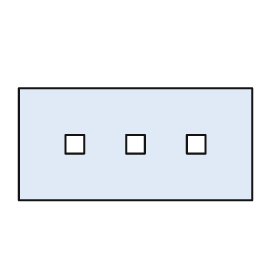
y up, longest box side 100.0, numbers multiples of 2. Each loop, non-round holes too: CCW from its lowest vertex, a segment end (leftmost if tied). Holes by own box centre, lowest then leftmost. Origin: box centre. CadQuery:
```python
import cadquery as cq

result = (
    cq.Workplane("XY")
    .moveTo(-50.0, -24.0)
    .lineTo(50.0, -24.0)
    .lineTo(50.0, 24.0)
    .lineTo(-50.0, 24.0)
    .close()
    .moveTo(-30.0, -4.0)
    .lineTo(-22.0, -4.0)
    .lineTo(-22.0, 4.0)
    .lineTo(-30.0, 4.0)
    .close()
    .moveTo(-4.0, -4.0)
    .lineTo(4.0, -4.0)
    .lineTo(4.0, 4.0)
    .lineTo(-4.0, 4.0)
    .close()
    .moveTo(22.0, -4.0)
    .lineTo(30.0, -4.0)
    .lineTo(30.0, 4.0)
    .lineTo(22.0, 4.0)
    .close()
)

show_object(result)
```